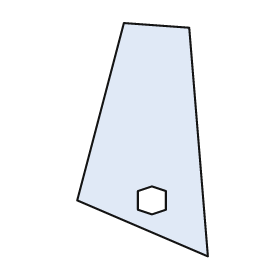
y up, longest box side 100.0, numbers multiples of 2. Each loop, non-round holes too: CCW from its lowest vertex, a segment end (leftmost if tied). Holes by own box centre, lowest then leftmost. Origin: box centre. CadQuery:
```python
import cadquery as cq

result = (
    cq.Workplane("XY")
    .moveTo(28.0, -50.0)
    .lineTo(20.0, 48.0)
    .lineTo(-8.0, 50.0)
    .lineTo(-28.0, -26.0)
    .close()
    .moveTo(4.0, -32.0)
    .lineTo(10.0, -30.0)
    .lineTo(10.0, -22.0)
    .lineTo(4.0, -20.0)
    .lineTo(-2.0, -22.0)
    .lineTo(-2.0, -30.0)
    .close()
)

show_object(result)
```